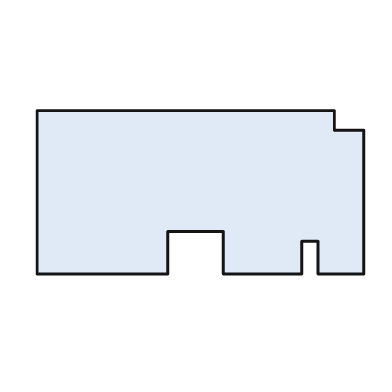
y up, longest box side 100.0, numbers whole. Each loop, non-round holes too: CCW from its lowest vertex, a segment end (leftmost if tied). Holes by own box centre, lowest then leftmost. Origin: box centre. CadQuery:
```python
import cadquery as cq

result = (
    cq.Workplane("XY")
    .moveTo(-50.0, -25.0)
    .lineTo(-10.0, -25.0)
    .lineTo(-10.0, -12.0)
    .lineTo(7.0, -12.0)
    .lineTo(7.0, -25.0)
    .lineTo(31.0, -25.0)
    .lineTo(31.0, -15.0)
    .lineTo(36.0, -15.0)
    .lineTo(36.0, -25.0)
    .lineTo(50.0, -25.0)
    .lineTo(50.0, 19.0)
    .lineTo(41.0, 19.0)
    .lineTo(41.0, 25.0)
    .lineTo(-50.0, 25.0)
    .close()
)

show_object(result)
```